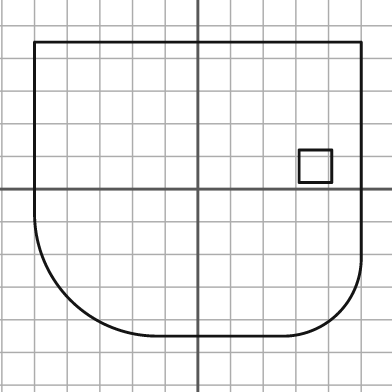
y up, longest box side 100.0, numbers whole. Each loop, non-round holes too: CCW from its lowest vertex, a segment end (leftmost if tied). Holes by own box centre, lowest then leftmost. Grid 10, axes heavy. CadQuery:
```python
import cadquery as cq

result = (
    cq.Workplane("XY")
    .moveTo(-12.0, -45.0)
    .lineTo(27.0, -45.0)
    .threePointArc((43.0, -38.0), (50.0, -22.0))
    .lineTo(50.0, 45.0)
    .lineTo(-50.0, 45.0)
    .lineTo(-50.0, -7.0)
    .threePointArc((-39.0, -34.0), (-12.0, -45.0))
    .close()
    .moveTo(31.0, 2.0)
    .lineTo(41.0, 2.0)
    .lineTo(41.0, 12.0)
    .lineTo(31.0, 12.0)
    .close()
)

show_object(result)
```